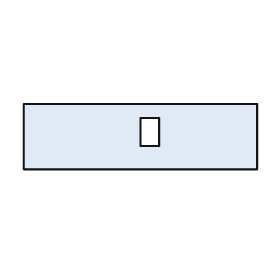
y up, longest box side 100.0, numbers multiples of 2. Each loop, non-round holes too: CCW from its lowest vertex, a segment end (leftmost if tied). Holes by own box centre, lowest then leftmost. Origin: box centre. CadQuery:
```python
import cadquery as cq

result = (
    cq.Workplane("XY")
    .moveTo(-50.0, -14.0)
    .lineTo(50.0, -14.0)
    .lineTo(50.0, 14.0)
    .lineTo(-50.0, 14.0)
    .close()
    .moveTo(0.0, -4.0)
    .lineTo(8.0, -4.0)
    .lineTo(8.0, 8.0)
    .lineTo(0.0, 8.0)
    .close()
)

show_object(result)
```